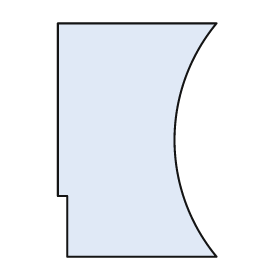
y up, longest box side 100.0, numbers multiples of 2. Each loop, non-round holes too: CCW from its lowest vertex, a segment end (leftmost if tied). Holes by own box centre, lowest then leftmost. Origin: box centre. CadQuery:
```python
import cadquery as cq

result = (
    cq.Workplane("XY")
    .moveTo(-30.0, -50.0)
    .lineTo(34.0, -50.0)
    .threePointArc((16.0, 0.0), (34.0, 50.0))
    .lineTo(-34.0, 50.0)
    .lineTo(-34.0, -24.0)
    .lineTo(-30.0, -24.0)
    .close()
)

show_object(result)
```